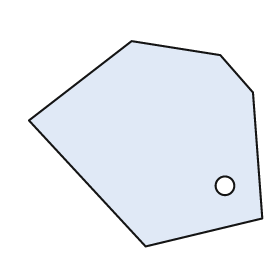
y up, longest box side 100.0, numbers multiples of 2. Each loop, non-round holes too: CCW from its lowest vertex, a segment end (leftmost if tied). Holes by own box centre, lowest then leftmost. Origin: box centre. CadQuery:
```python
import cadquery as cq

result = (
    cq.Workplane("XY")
    .moveTo(0.0, -44.0)
    .lineTo(50.0, -32.0)
    .lineTo(46.0, 22.0)
    .lineTo(32.0, 38.0)
    .lineTo(-6.0, 44.0)
    .lineTo(-50.0, 10.0)
    .close()
    .moveTo(34.0, -18.0)
    .circle(4.0)
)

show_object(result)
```